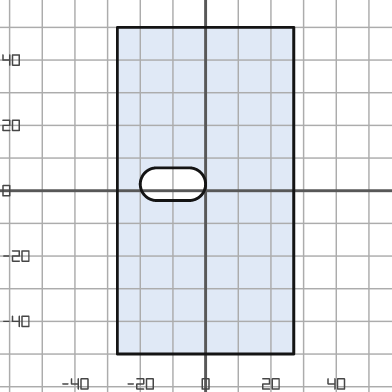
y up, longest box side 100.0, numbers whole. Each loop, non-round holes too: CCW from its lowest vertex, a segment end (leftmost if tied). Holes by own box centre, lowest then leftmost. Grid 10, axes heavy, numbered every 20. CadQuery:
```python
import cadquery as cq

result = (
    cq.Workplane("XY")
    .moveTo(-27.0, -50.0)
    .lineTo(27.0, -50.0)
    .lineTo(27.0, 50.0)
    .lineTo(-27.0, 50.0)
    .close()
    .moveTo(-15.0, -3.0)
    .lineTo(-5.0, -3.0)
    .threePointArc((0.0, 2.0), (-5.0, 7.0))
    .lineTo(-15.0, 7.0)
    .threePointArc((-20.0, 2.0), (-15.0, -3.0))
    .close()
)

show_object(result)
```